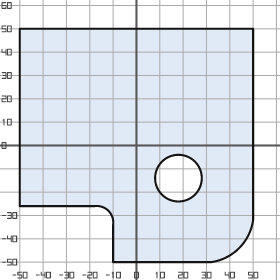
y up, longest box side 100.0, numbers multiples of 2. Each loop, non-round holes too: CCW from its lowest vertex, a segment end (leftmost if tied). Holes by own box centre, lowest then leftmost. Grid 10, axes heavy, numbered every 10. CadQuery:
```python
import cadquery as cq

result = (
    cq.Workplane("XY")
    .moveTo(-10.0, -50.0)
    .lineTo(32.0, -50.0)
    .threePointArc((44.0, -44.0), (50.0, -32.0))
    .lineTo(50.0, 50.0)
    .lineTo(-50.0, 50.0)
    .lineTo(-50.0, -26.0)
    .lineTo(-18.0, -26.0)
    .threePointArc((-12.0, -28.0), (-10.0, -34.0))
    .close()
    .moveTo(18.0, -14.0)
    .circle(10.0)
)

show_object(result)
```